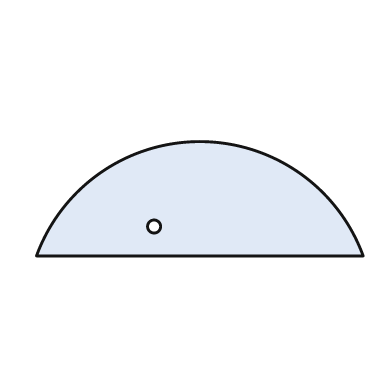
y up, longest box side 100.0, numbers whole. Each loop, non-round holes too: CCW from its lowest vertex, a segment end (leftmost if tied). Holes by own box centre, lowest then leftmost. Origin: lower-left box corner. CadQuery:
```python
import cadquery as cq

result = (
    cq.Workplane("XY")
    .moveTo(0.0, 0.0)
    .lineTo(100.0, 0.0)
    .threePointArc((50.0, 35.0), (0.0, 0.0))
    .close()
    .moveTo(36.0, 9.0)
    .circle(2.0)
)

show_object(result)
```